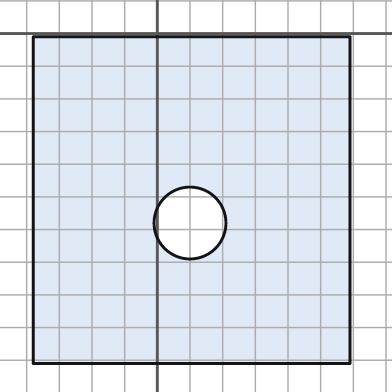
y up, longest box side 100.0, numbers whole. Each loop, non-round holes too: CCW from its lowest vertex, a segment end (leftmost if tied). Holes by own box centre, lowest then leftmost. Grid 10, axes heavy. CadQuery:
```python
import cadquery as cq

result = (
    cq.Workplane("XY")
    .moveTo(-38.0, -101.0)
    .lineTo(59.0, -101.0)
    .lineTo(59.0, -1.0)
    .lineTo(-38.0, -1.0)
    .close()
    .moveTo(10.0, -58.0)
    .circle(11.0)
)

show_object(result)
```